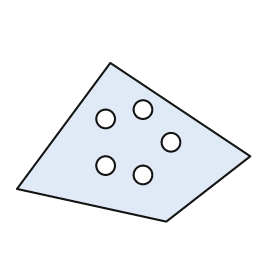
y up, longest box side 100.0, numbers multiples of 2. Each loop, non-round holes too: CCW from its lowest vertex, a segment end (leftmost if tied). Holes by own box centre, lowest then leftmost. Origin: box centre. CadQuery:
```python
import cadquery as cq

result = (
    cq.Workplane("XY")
    .moveTo(14.0, -34.0)
    .lineTo(50.0, -6.0)
    .lineTo(-10.0, 34.0)
    .lineTo(-50.0, -20.0)
    .close()
    .moveTo(4.0, -14.0)
    .circle(4.0)
    .moveTo(-12.0, -10.0)
    .circle(4.0)
    .moveTo(16.0, 0.0)
    .circle(4.0)
    .moveTo(-12.0, 10.0)
    .circle(4.0)
    .moveTo(4.0, 14.0)
    .circle(4.0)
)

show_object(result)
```